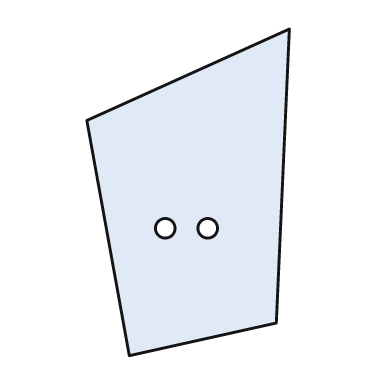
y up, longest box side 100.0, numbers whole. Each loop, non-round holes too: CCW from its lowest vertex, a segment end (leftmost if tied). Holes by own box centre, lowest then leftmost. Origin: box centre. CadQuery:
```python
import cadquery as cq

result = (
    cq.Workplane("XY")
    .moveTo(-18.0, -50.0)
    .lineTo(27.0, -40.0)
    .lineTo(31.0, 50.0)
    .lineTo(-31.0, 22.0)
    .close()
    .moveTo(-7.0, -11.0)
    .circle(3.0)
    .moveTo(6.0, -11.0)
    .circle(3.0)
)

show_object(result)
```